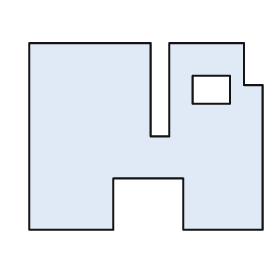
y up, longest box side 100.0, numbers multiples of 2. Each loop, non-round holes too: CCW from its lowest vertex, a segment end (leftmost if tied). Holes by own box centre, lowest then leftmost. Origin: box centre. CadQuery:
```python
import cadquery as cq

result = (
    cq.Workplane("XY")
    .moveTo(-50.0, -40.0)
    .lineTo(-14.0, -40.0)
    .lineTo(-14.0, -18.0)
    .lineTo(16.0, -18.0)
    .lineTo(16.0, -40.0)
    .lineTo(50.0, -40.0)
    .lineTo(50.0, 22.0)
    .lineTo(42.0, 22.0)
    .lineTo(42.0, 40.0)
    .lineTo(10.0, 40.0)
    .lineTo(10.0, 0.0)
    .lineTo(2.0, 0.0)
    .lineTo(2.0, 40.0)
    .lineTo(-50.0, 40.0)
    .close()
    .moveTo(20.0, 14.0)
    .lineTo(36.0, 14.0)
    .lineTo(36.0, 26.0)
    .lineTo(20.0, 26.0)
    .close()
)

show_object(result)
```